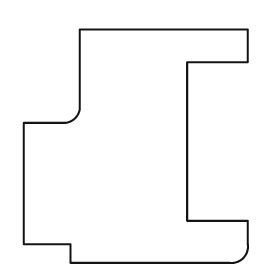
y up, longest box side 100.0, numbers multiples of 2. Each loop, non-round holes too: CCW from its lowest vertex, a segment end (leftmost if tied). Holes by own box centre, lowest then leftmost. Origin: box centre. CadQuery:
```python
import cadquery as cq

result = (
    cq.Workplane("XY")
    .moveTo(-28.0, -50.0)
    .lineTo(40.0, -50.0)
    .threePointArc((46.0, -48.0), (48.0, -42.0))
    .lineTo(48.0, -32.0)
    .lineTo(22.0, -32.0)
    .lineTo(22.0, 36.0)
    .lineTo(48.0, 36.0)
    .lineTo(48.0, 50.0)
    .lineTo(-24.0, 50.0)
    .lineTo(-24.0, 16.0)
    .threePointArc((-26.0, 12.0), (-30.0, 10.0))
    .lineTo(-48.0, 10.0)
    .lineTo(-48.0, -42.0)
    .lineTo(-28.0, -42.0)
    .close()
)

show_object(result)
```